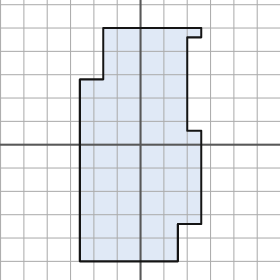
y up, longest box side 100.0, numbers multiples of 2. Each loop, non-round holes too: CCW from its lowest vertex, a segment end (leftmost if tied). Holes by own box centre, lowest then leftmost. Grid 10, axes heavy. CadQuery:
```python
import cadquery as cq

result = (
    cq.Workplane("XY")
    .moveTo(-26.0, -50.0)
    .lineTo(16.0, -50.0)
    .lineTo(16.0, -34.0)
    .lineTo(26.0, -34.0)
    .lineTo(26.0, 6.0)
    .lineTo(20.0, 6.0)
    .lineTo(20.0, 46.0)
    .lineTo(26.0, 46.0)
    .lineTo(26.0, 50.0)
    .lineTo(-16.0, 50.0)
    .lineTo(-16.0, 28.0)
    .lineTo(-26.0, 28.0)
    .close()
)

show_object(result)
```